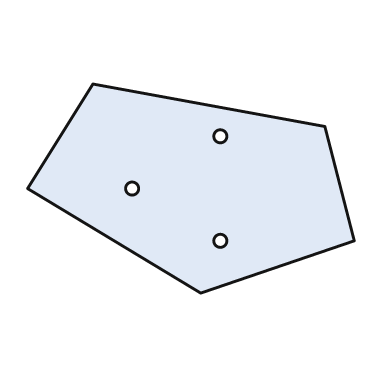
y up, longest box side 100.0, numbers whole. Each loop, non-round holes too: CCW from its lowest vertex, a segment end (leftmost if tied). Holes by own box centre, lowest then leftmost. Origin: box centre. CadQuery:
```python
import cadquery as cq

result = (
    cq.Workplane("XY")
    .moveTo(3.0, -32.0)
    .lineTo(50.0, -16.0)
    .lineTo(41.0, 19.0)
    .lineTo(-30.0, 32.0)
    .lineTo(-50.0, 0.0)
    .close()
    .moveTo(9.0, -16.0)
    .circle(2.0)
    .moveTo(-18.0, 0.0)
    .circle(2.0)
    .moveTo(9.0, 16.0)
    .circle(2.0)
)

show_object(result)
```